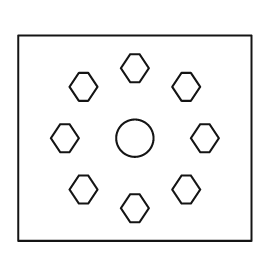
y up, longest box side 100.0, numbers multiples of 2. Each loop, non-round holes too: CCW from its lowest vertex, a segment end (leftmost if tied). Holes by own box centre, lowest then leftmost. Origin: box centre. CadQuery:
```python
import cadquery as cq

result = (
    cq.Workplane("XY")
    .moveTo(-50.0, -44.0)
    .lineTo(50.0, -44.0)
    .lineTo(50.0, 44.0)
    .lineTo(-50.0, 44.0)
    .close()
    .moveTo(-2.0, -36.0)
    .lineTo(2.0, -36.0)
    .lineTo(6.0, -30.0)
    .lineTo(2.0, -24.0)
    .lineTo(-2.0, -24.0)
    .lineTo(-6.0, -30.0)
    .close()
    .moveTo(-24.0, -28.0)
    .lineTo(-20.0, -28.0)
    .lineTo(-16.0, -22.0)
    .lineTo(-20.0, -16.0)
    .lineTo(-24.0, -16.0)
    .lineTo(-28.0, -22.0)
    .close()
    .moveTo(20.0, -28.0)
    .lineTo(24.0, -28.0)
    .lineTo(28.0, -22.0)
    .lineTo(24.0, -16.0)
    .lineTo(20.0, -16.0)
    .lineTo(16.0, -22.0)
    .close()
    .moveTo(-32.0, -6.0)
    .lineTo(-28.0, -6.0)
    .lineTo(-24.0, 0.0)
    .lineTo(-28.0, 6.0)
    .lineTo(-32.0, 6.0)
    .lineTo(-36.0, 0.0)
    .close()
    .moveTo(0.0, 0.0)
    .circle(8.0)
    .moveTo(28.0, -6.0)
    .lineTo(32.0, -6.0)
    .lineTo(36.0, 0.0)
    .lineTo(32.0, 6.0)
    .lineTo(28.0, 6.0)
    .lineTo(24.0, 0.0)
    .close()
    .moveTo(-24.0, 16.0)
    .lineTo(-20.0, 16.0)
    .lineTo(-16.0, 22.0)
    .lineTo(-20.0, 28.0)
    .lineTo(-24.0, 28.0)
    .lineTo(-28.0, 22.0)
    .close()
    .moveTo(20.0, 16.0)
    .lineTo(24.0, 16.0)
    .lineTo(28.0, 22.0)
    .lineTo(24.0, 28.0)
    .lineTo(20.0, 28.0)
    .lineTo(16.0, 22.0)
    .close()
    .moveTo(-2.0, 24.0)
    .lineTo(2.0, 24.0)
    .lineTo(6.0, 30.0)
    .lineTo(2.0, 36.0)
    .lineTo(-2.0, 36.0)
    .lineTo(-6.0, 30.0)
    .close()
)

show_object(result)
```